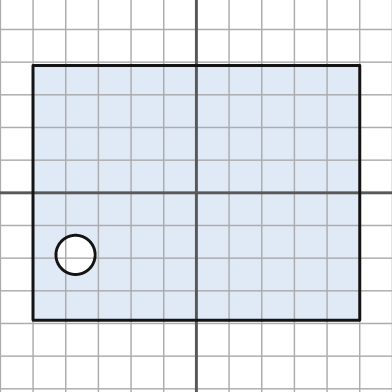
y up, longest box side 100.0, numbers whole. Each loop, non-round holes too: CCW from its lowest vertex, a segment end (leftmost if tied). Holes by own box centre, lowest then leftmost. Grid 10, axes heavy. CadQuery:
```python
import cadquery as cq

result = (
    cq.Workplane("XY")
    .moveTo(-50.0, -39.0)
    .lineTo(50.0, -39.0)
    .lineTo(50.0, 39.0)
    .lineTo(-50.0, 39.0)
    .close()
    .moveTo(-37.0, -19.0)
    .circle(6.0)
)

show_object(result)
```